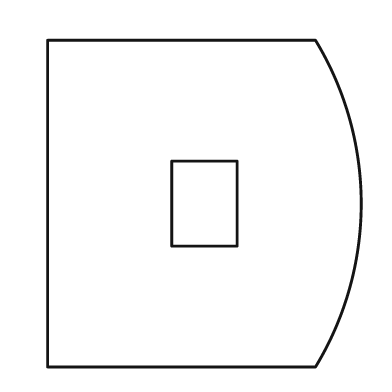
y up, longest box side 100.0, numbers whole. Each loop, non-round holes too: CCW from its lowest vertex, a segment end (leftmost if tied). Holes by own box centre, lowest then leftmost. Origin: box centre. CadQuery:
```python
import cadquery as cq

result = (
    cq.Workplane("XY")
    .moveTo(-48.0, -50.0)
    .lineTo(34.0, -50.0)
    .threePointArc((48.0, 0.0), (34.0, 50.0))
    .lineTo(-48.0, 50.0)
    .close()
    .moveTo(-10.0, -13.0)
    .lineTo(10.0, -13.0)
    .lineTo(10.0, 13.0)
    .lineTo(-10.0, 13.0)
    .close()
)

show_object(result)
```